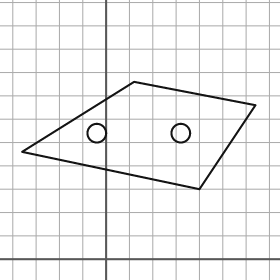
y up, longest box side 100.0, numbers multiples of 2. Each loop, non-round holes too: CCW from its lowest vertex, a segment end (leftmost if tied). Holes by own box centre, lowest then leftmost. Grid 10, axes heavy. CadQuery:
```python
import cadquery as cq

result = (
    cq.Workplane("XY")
    .moveTo(40.0, 30.0)
    .lineTo(64.0, 66.0)
    .lineTo(12.0, 76.0)
    .lineTo(-36.0, 46.0)
    .close()
    .moveTo(-4.0, 54.0)
    .circle(4.0)
    .moveTo(32.0, 54.0)
    .circle(4.0)
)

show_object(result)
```